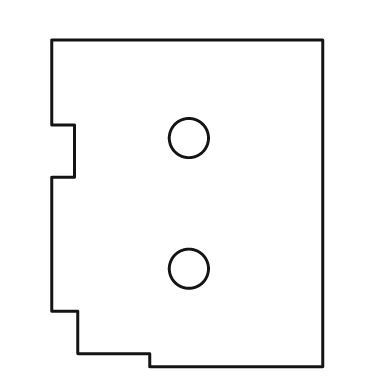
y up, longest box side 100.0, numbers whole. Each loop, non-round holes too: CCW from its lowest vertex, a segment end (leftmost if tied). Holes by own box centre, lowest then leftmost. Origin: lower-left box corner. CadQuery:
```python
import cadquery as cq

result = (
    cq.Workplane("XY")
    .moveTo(30.0, 0.0)
    .lineTo(83.0, 0.0)
    .lineTo(83.0, 100.0)
    .lineTo(0.0, 100.0)
    .lineTo(0.0, 74.0)
    .lineTo(7.0, 74.0)
    .lineTo(7.0, 58.0)
    .lineTo(0.0, 58.0)
    .lineTo(0.0, 17.0)
    .lineTo(8.0, 17.0)
    .lineTo(8.0, 4.0)
    .lineTo(30.0, 4.0)
    .close()
    .moveTo(42.0, 30.0)
    .circle(6.0)
    .moveTo(42.0, 70.0)
    .circle(6.0)
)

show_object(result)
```